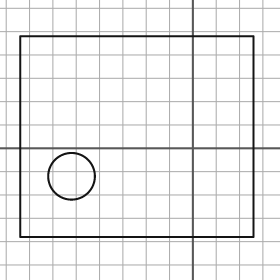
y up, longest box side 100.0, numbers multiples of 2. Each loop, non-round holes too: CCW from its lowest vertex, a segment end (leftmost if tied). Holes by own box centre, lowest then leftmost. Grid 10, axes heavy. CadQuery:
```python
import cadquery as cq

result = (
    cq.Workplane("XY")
    .moveTo(-74.0, -38.0)
    .lineTo(26.0, -38.0)
    .lineTo(26.0, 48.0)
    .lineTo(-74.0, 48.0)
    .close()
    .moveTo(-52.0, -12.0)
    .circle(10.0)
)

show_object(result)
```